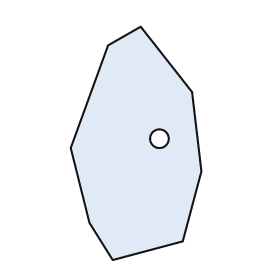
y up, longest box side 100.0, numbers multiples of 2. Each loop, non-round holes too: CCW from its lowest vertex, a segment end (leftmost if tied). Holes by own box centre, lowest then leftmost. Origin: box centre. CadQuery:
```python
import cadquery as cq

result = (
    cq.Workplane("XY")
    .moveTo(-10.0, -50.0)
    .lineTo(20.0, -42.0)
    .lineTo(28.0, -12.0)
    .lineTo(24.0, 22.0)
    .lineTo(2.0, 50.0)
    .lineTo(-12.0, 42.0)
    .lineTo(-28.0, -2.0)
    .lineTo(-20.0, -34.0)
    .close()
    .moveTo(10.0, 2.0)
    .circle(4.0)
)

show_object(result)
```